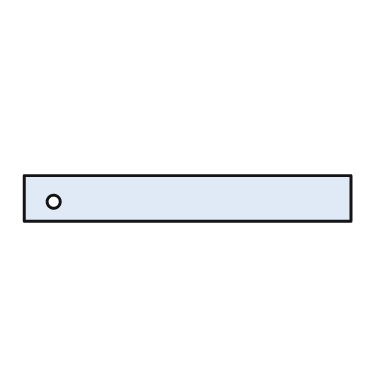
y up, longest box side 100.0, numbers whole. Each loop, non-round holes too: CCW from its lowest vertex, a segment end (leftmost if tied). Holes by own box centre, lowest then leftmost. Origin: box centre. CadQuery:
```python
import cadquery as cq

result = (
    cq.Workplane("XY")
    .moveTo(-50.0, -7.0)
    .lineTo(50.0, -7.0)
    .lineTo(50.0, 7.0)
    .lineTo(-50.0, 7.0)
    .close()
    .moveTo(-41.0, -1.0)
    .circle(2.0)
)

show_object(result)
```